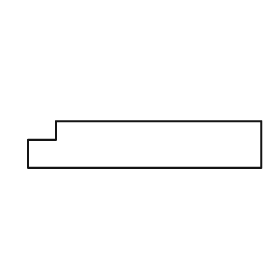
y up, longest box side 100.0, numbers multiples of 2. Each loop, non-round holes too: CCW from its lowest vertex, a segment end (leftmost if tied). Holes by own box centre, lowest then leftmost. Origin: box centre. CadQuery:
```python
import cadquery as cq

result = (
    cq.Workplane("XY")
    .moveTo(-50.0, -10.0)
    .lineTo(50.0, -10.0)
    .lineTo(50.0, 10.0)
    .lineTo(-38.0, 10.0)
    .lineTo(-38.0, 2.0)
    .lineTo(-50.0, 2.0)
    .close()
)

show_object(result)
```